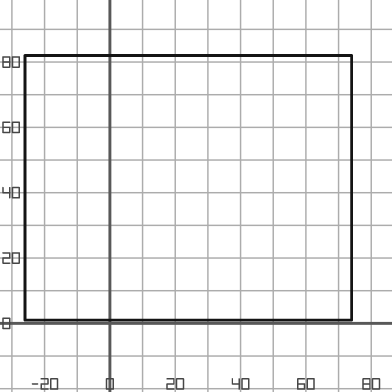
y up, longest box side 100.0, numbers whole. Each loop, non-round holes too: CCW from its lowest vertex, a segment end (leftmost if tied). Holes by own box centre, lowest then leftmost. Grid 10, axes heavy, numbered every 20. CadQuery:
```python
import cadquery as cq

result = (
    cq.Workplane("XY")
    .moveTo(-26.0, 1.0)
    .lineTo(74.0, 1.0)
    .lineTo(74.0, 82.0)
    .lineTo(-26.0, 82.0)
    .close()
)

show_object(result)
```